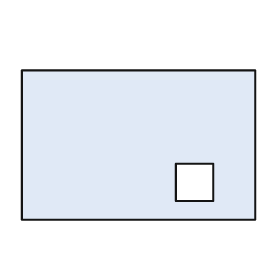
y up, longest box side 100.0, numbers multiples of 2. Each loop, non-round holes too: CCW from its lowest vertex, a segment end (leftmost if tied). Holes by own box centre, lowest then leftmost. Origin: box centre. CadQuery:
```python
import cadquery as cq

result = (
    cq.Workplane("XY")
    .moveTo(-50.0, -32.0)
    .lineTo(50.0, -32.0)
    .lineTo(50.0, 32.0)
    .lineTo(-50.0, 32.0)
    .close()
    .moveTo(16.0, -24.0)
    .lineTo(32.0, -24.0)
    .lineTo(32.0, -8.0)
    .lineTo(16.0, -8.0)
    .close()
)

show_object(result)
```